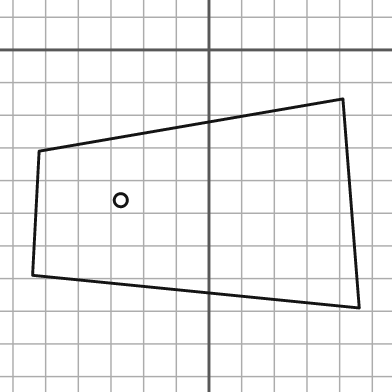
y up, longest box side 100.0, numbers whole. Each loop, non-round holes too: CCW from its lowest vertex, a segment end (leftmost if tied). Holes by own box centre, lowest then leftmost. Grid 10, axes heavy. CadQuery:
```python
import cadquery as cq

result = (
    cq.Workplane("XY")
    .moveTo(46.0, -79.0)
    .lineTo(41.0, -15.0)
    .lineTo(-52.0, -31.0)
    .lineTo(-54.0, -69.0)
    .close()
    .moveTo(-27.0, -46.0)
    .circle(2.0)
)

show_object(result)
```